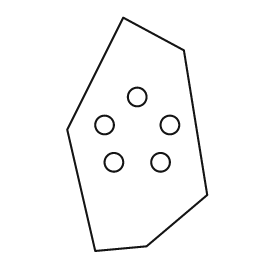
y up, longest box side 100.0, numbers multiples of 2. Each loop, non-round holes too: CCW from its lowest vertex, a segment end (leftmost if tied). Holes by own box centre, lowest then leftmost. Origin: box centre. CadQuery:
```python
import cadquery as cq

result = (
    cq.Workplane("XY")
    .moveTo(-18.0, -50.0)
    .lineTo(4.0, -48.0)
    .lineTo(30.0, -26.0)
    .lineTo(20.0, 36.0)
    .lineTo(-6.0, 50.0)
    .lineTo(-30.0, 2.0)
    .close()
    .moveTo(-10.0, -12.0)
    .circle(4.0)
    .moveTo(10.0, -12.0)
    .circle(4.0)
    .moveTo(-14.0, 4.0)
    .circle(4.0)
    .moveTo(14.0, 4.0)
    .circle(4.0)
    .moveTo(0.0, 16.0)
    .circle(4.0)
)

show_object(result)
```